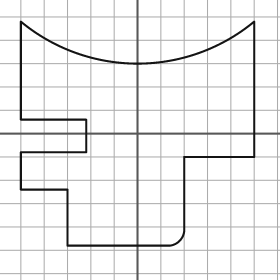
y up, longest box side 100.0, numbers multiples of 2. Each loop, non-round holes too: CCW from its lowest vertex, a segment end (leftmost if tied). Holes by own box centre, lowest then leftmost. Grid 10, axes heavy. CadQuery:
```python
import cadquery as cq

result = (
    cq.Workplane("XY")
    .moveTo(-30.0, -48.0)
    .lineTo(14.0, -48.0)
    .threePointArc((18.0, -46.0), (20.0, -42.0))
    .lineTo(20.0, -10.0)
    .lineTo(50.0, -10.0)
    .lineTo(50.0, 48.0)
    .threePointArc((0.0, 30.0), (-50.0, 48.0))
    .lineTo(-50.0, 6.0)
    .lineTo(-22.0, 6.0)
    .lineTo(-22.0, -8.0)
    .lineTo(-50.0, -8.0)
    .lineTo(-50.0, -24.0)
    .lineTo(-30.0, -24.0)
    .close()
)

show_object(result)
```